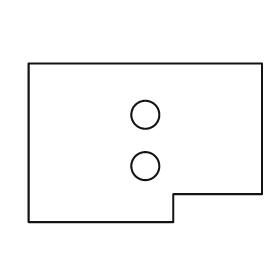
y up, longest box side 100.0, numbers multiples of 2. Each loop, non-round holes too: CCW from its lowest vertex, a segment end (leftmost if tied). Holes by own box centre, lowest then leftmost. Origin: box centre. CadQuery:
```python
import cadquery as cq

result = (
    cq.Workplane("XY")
    .moveTo(-50.0, -34.0)
    .lineTo(12.0, -34.0)
    .lineTo(12.0, -22.0)
    .lineTo(50.0, -22.0)
    .lineTo(50.0, 34.0)
    .lineTo(-50.0, 34.0)
    .close()
    .moveTo(0.0, -10.0)
    .circle(6.0)
    .moveTo(0.0, 12.0)
    .circle(6.0)
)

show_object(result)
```